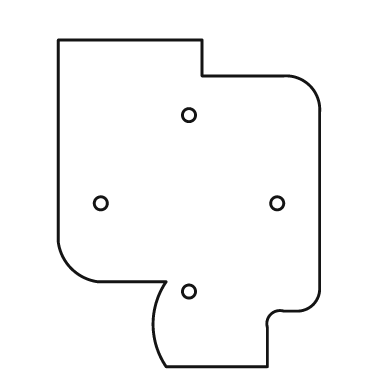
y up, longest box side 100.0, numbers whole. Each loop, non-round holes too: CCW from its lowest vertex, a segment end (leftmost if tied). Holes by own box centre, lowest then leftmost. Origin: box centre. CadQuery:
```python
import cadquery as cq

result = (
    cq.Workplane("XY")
    .moveTo(-7.0, -50.0)
    .lineTo(24.0, -50.0)
    .lineTo(24.0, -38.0)
    .threePointArc((25.0, -34.0), (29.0, -33.0))
    .lineTo(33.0, -33.0)
    .threePointArc((38.0, -31.0), (40.0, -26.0))
    .lineTo(40.0, 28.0)
    .threePointArc((37.0, 36.0), (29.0, 39.0))
    .lineTo(4.0, 39.0)
    .lineTo(4.0, 50.0)
    .lineTo(-40.0, 50.0)
    .lineTo(-40.0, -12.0)
    .threePointArc((-36.0, -20.0), (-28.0, -24.0))
    .lineTo(-7.0, -24.0)
    .threePointArc((-11.0, -37.0), (-7.0, -50.0))
    .close()
    .moveTo(0.0, -27.0)
    .circle(2.0)
    .moveTo(-27.0, 0.0)
    .circle(2.0)
    .moveTo(27.0, 0.0)
    .circle(2.0)
    .moveTo(0.0, 27.0)
    .circle(2.0)
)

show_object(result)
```